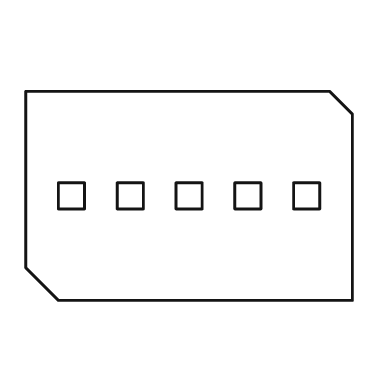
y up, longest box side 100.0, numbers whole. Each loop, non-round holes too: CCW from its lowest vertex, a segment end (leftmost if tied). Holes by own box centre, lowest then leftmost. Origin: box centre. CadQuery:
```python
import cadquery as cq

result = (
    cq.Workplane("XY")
    .moveTo(-40.0, -32.0)
    .lineTo(50.0, -32.0)
    .lineTo(50.0, 25.0)
    .lineTo(43.0, 32.0)
    .lineTo(-50.0, 32.0)
    .lineTo(-50.0, -22.0)
    .close()
    .moveTo(-40.0, -4.0)
    .lineTo(-32.0, -4.0)
    .lineTo(-32.0, 4.0)
    .lineTo(-40.0, 4.0)
    .close()
    .moveTo(-22.0, -4.0)
    .lineTo(-14.0, -4.0)
    .lineTo(-14.0, 4.0)
    .lineTo(-22.0, 4.0)
    .close()
    .moveTo(-4.0, -4.0)
    .lineTo(4.0, -4.0)
    .lineTo(4.0, 4.0)
    .lineTo(-4.0, 4.0)
    .close()
    .moveTo(14.0, -4.0)
    .lineTo(22.0, -4.0)
    .lineTo(22.0, 4.0)
    .lineTo(14.0, 4.0)
    .close()
    .moveTo(32.0, -4.0)
    .lineTo(40.0, -4.0)
    .lineTo(40.0, 4.0)
    .lineTo(32.0, 4.0)
    .close()
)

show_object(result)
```